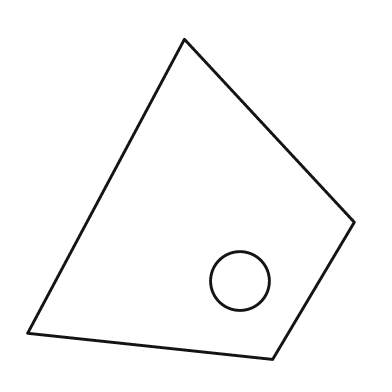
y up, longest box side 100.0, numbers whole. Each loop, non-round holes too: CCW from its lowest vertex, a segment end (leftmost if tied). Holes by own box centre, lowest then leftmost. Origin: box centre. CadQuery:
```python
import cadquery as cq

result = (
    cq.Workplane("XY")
    .moveTo(25.0, -49.0)
    .lineTo(50.0, -7.0)
    .lineTo(-2.0, 49.0)
    .lineTo(-50.0, -41.0)
    .close()
    .moveTo(15.0, -25.0)
    .circle(9.0)
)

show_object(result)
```